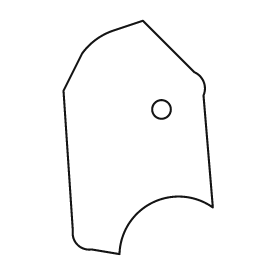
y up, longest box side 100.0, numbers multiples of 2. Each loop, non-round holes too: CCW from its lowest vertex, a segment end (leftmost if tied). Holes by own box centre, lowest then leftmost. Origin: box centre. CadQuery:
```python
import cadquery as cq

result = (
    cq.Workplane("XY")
    .moveTo(-8.0, -50.0)
    .threePointArc((6.0, -28.0), (32.0, -30.0))
    .lineTo(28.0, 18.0)
    .threePointArc((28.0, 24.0), (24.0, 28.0))
    .lineTo(2.0, 50.0)
    .lineTo(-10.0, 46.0)
    .threePointArc((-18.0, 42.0), (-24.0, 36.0))
    .lineTo(-32.0, 20.0)
    .lineTo(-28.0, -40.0)
    .threePointArc((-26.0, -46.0), (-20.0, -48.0))
    .close()
    .moveTo(10.0, 12.0)
    .circle(4.0)
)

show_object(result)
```